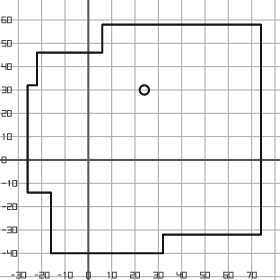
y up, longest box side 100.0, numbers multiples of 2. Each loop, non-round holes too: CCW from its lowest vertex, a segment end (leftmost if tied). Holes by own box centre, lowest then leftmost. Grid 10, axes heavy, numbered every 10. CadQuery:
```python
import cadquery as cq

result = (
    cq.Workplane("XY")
    .moveTo(-16.0, -40.0)
    .lineTo(32.0, -40.0)
    .lineTo(32.0, -32.0)
    .lineTo(74.0, -32.0)
    .lineTo(74.0, 58.0)
    .lineTo(6.0, 58.0)
    .lineTo(6.0, 46.0)
    .lineTo(-22.0, 46.0)
    .lineTo(-22.0, 32.0)
    .lineTo(-26.0, 32.0)
    .lineTo(-26.0, -14.0)
    .lineTo(-16.0, -14.0)
    .close()
    .moveTo(24.0, 30.0)
    .circle(2.0)
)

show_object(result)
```